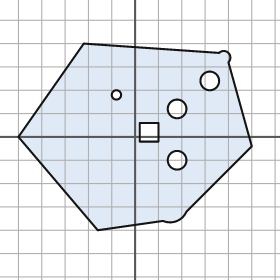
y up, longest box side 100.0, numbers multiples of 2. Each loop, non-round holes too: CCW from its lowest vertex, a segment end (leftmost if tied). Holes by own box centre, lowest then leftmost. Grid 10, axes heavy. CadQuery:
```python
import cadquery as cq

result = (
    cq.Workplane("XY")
    .moveTo(-16.0, -40.0)
    .lineTo(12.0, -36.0)
    .threePointArc((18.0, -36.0), (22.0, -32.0))
    .lineTo(50.0, -4.0)
    .lineTo(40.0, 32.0)
    .threePointArc((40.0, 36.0), (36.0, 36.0))
    .lineTo(-22.0, 40.0)
    .lineTo(-50.0, 0.0)
    .close()
    .moveTo(18.0, -10.0)
    .circle(4.0)
    .moveTo(2.0, -2.0)
    .lineTo(10.0, -2.0)
    .lineTo(10.0, 6.0)
    .lineTo(2.0, 6.0)
    .close()
    .moveTo(18.0, 12.0)
    .circle(4.0)
    .moveTo(-8.0, 18.0)
    .circle(2.0)
    .moveTo(32.0, 24.0)
    .circle(4.0)
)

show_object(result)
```